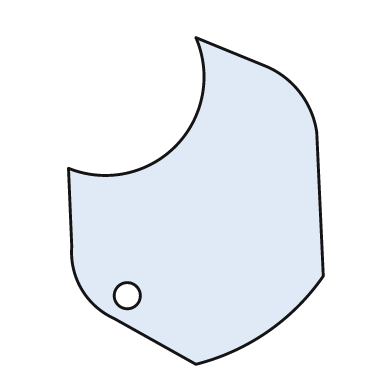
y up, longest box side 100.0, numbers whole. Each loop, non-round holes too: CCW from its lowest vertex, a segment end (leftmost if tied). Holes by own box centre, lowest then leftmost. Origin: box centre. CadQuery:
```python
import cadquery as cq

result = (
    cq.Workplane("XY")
    .moveTo(0.0, -50.0)
    .threePointArc((22.0, -40.0), (39.0, -23.0))
    .lineTo(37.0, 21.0)
    .threePointArc((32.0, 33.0), (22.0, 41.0))
    .lineTo(0.0, 50.0)
    .threePointArc((-6.0, 17.0), (-39.0, 10.0))
    .lineTo(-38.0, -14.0)
    .threePointArc((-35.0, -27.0), (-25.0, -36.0))
    .close()
    .moveTo(-21.0, -29.0)
    .circle(4.0)
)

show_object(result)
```